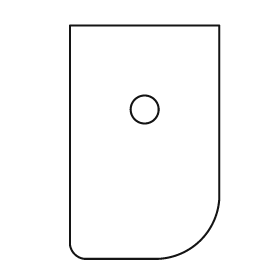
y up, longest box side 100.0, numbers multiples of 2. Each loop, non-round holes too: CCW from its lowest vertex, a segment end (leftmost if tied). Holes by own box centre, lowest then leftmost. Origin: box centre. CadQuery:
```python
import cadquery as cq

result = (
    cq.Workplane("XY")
    .moveTo(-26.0, -50.0)
    .lineTo(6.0, -50.0)
    .threePointArc((24.0, -42.0), (32.0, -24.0))
    .lineTo(32.0, 50.0)
    .lineTo(-32.0, 50.0)
    .lineTo(-32.0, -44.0)
    .threePointArc((-30.0, -48.0), (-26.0, -50.0))
    .close()
    .moveTo(0.0, 14.0)
    .circle(6.0)
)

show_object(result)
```